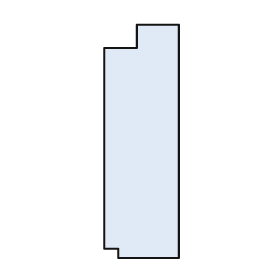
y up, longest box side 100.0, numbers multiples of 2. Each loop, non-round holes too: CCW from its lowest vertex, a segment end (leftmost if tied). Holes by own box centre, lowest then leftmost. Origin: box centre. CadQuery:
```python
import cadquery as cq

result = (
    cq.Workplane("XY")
    .moveTo(-10.0, -50.0)
    .lineTo(16.0, -50.0)
    .lineTo(16.0, 50.0)
    .lineTo(-2.0, 50.0)
    .lineTo(-2.0, 40.0)
    .lineTo(-16.0, 40.0)
    .lineTo(-16.0, -46.0)
    .lineTo(-10.0, -46.0)
    .close()
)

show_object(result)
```